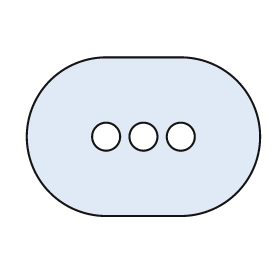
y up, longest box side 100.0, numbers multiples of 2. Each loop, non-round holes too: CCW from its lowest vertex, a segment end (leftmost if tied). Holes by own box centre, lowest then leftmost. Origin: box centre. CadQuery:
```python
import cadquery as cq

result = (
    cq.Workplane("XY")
    .moveTo(-16.0, -34.0)
    .lineTo(16.0, -34.0)
    .threePointArc((50.0, 0.0), (16.0, 34.0))
    .lineTo(-16.0, 34.0)
    .threePointArc((-50.0, 0.0), (-16.0, -34.0))
    .close()
    .moveTo(-16.0, 0.0)
    .circle(6.0)
    .moveTo(0.0, 0.0)
    .circle(6.0)
    .moveTo(16.0, 0.0)
    .circle(6.0)
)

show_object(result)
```